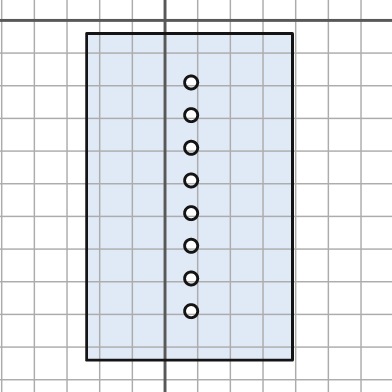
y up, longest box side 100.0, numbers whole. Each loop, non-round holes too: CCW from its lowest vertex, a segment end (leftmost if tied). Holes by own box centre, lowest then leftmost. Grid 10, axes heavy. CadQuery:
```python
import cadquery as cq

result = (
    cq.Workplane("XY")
    .moveTo(-24.0, -104.0)
    .lineTo(39.0, -104.0)
    .lineTo(39.0, -4.0)
    .lineTo(-24.0, -4.0)
    .close()
    .moveTo(8.0, -89.0)
    .circle(2.0)
    .moveTo(8.0, -79.0)
    .circle(2.0)
    .moveTo(8.0, -69.0)
    .circle(2.0)
    .moveTo(8.0, -59.0)
    .circle(2.0)
    .moveTo(8.0, -49.0)
    .circle(2.0)
    .moveTo(8.0, -39.0)
    .circle(2.0)
    .moveTo(8.0, -29.0)
    .circle(2.0)
    .moveTo(8.0, -19.0)
    .circle(2.0)
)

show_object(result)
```